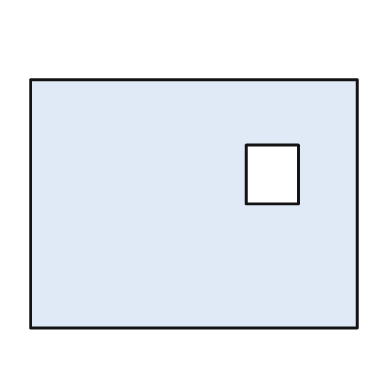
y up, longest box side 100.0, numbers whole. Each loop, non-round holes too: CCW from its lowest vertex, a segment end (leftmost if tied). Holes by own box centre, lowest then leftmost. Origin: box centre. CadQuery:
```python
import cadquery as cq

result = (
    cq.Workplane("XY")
    .moveTo(-50.0, -38.0)
    .lineTo(50.0, -38.0)
    .lineTo(50.0, 38.0)
    .lineTo(-50.0, 38.0)
    .close()
    .moveTo(16.0, 0.0)
    .lineTo(32.0, 0.0)
    .lineTo(32.0, 18.0)
    .lineTo(16.0, 18.0)
    .close()
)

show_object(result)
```